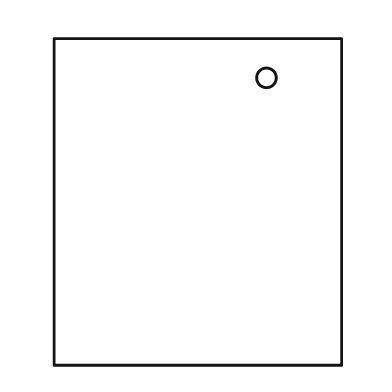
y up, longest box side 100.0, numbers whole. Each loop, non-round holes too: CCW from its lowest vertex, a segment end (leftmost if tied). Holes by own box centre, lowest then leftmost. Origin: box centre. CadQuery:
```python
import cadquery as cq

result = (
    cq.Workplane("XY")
    .moveTo(-44.0, -50.0)
    .lineTo(44.0, -50.0)
    .lineTo(44.0, 50.0)
    .lineTo(-44.0, 50.0)
    .close()
    .moveTo(21.0, 38.0)
    .circle(3.0)
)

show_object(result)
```